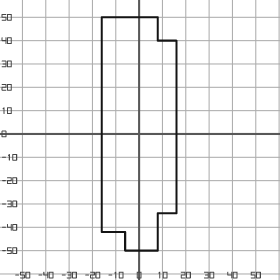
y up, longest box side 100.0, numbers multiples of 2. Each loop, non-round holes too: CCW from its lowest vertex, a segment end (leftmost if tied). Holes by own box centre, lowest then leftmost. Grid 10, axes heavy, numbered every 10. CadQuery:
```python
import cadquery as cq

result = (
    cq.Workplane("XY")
    .moveTo(-6.0, -50.0)
    .lineTo(8.0, -50.0)
    .lineTo(8.0, -34.0)
    .lineTo(16.0, -34.0)
    .lineTo(16.0, 40.0)
    .lineTo(8.0, 40.0)
    .lineTo(8.0, 50.0)
    .lineTo(-16.0, 50.0)
    .lineTo(-16.0, -42.0)
    .lineTo(-6.0, -42.0)
    .close()
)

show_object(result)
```